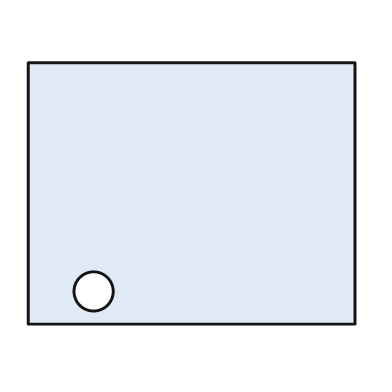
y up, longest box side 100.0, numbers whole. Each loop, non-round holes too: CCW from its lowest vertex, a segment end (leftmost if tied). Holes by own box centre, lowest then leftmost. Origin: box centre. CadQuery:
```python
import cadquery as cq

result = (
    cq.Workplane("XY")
    .moveTo(-50.0, -40.0)
    .lineTo(50.0, -40.0)
    .lineTo(50.0, 40.0)
    .lineTo(-50.0, 40.0)
    .close()
    .moveTo(-30.0, -30.0)
    .circle(6.0)
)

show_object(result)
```